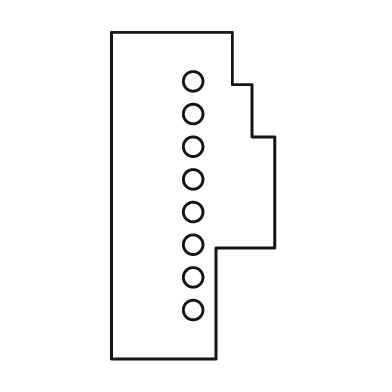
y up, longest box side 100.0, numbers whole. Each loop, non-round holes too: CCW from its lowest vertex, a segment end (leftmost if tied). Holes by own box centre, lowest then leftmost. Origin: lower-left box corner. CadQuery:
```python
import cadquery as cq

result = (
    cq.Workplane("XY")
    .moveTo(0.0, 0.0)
    .lineTo(32.0, 0.0)
    .lineTo(32.0, 34.0)
    .lineTo(50.0, 34.0)
    .lineTo(50.0, 68.0)
    .lineTo(43.0, 68.0)
    .lineTo(43.0, 84.0)
    .lineTo(37.0, 84.0)
    .lineTo(37.0, 100.0)
    .lineTo(0.0, 100.0)
    .close()
    .moveTo(25.0, 15.0)
    .circle(3.0)
    .moveTo(25.0, 25.0)
    .circle(3.0)
    .moveTo(25.0, 35.0)
    .circle(3.0)
    .moveTo(25.0, 45.0)
    .circle(3.0)
    .moveTo(25.0, 55.0)
    .circle(3.0)
    .moveTo(25.0, 65.0)
    .circle(3.0)
    .moveTo(25.0, 75.0)
    .circle(3.0)
    .moveTo(25.0, 85.0)
    .circle(3.0)
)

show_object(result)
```